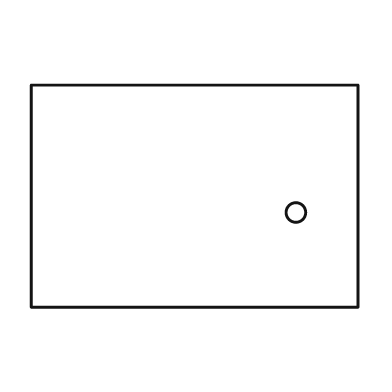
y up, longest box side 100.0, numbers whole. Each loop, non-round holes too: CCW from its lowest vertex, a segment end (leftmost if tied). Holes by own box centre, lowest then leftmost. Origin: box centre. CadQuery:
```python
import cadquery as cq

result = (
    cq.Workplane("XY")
    .moveTo(-50.0, -34.0)
    .lineTo(50.0, -34.0)
    .lineTo(50.0, 34.0)
    .lineTo(-50.0, 34.0)
    .close()
    .moveTo(31.0, -5.0)
    .circle(3.0)
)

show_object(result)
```